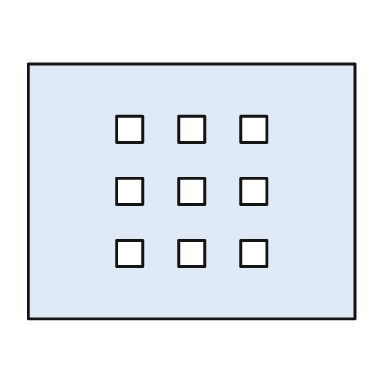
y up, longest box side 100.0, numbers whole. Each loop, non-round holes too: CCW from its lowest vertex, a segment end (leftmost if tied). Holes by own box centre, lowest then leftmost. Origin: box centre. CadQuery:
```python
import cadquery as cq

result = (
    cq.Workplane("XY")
    .moveTo(-50.0, -39.0)
    .lineTo(50.0, -39.0)
    .lineTo(50.0, 39.0)
    .lineTo(-50.0, 39.0)
    .close()
    .moveTo(-23.0, -23.0)
    .lineTo(-15.0, -23.0)
    .lineTo(-15.0, -15.0)
    .lineTo(-23.0, -15.0)
    .close()
    .moveTo(-4.0, -23.0)
    .lineTo(4.0, -23.0)
    .lineTo(4.0, -15.0)
    .lineTo(-4.0, -15.0)
    .close()
    .moveTo(15.0, -23.0)
    .lineTo(23.0, -23.0)
    .lineTo(23.0, -15.0)
    .lineTo(15.0, -15.0)
    .close()
    .moveTo(-23.0, -4.0)
    .lineTo(-15.0, -4.0)
    .lineTo(-15.0, 4.0)
    .lineTo(-23.0, 4.0)
    .close()
    .moveTo(-4.0, -4.0)
    .lineTo(4.0, -4.0)
    .lineTo(4.0, 4.0)
    .lineTo(-4.0, 4.0)
    .close()
    .moveTo(15.0, -4.0)
    .lineTo(23.0, -4.0)
    .lineTo(23.0, 4.0)
    .lineTo(15.0, 4.0)
    .close()
    .moveTo(-23.0, 15.0)
    .lineTo(-15.0, 15.0)
    .lineTo(-15.0, 23.0)
    .lineTo(-23.0, 23.0)
    .close()
    .moveTo(-4.0, 15.0)
    .lineTo(4.0, 15.0)
    .lineTo(4.0, 23.0)
    .lineTo(-4.0, 23.0)
    .close()
    .moveTo(15.0, 15.0)
    .lineTo(23.0, 15.0)
    .lineTo(23.0, 23.0)
    .lineTo(15.0, 23.0)
    .close()
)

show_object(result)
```